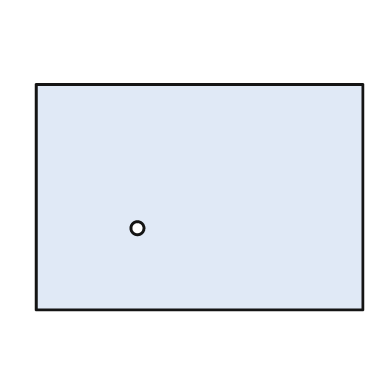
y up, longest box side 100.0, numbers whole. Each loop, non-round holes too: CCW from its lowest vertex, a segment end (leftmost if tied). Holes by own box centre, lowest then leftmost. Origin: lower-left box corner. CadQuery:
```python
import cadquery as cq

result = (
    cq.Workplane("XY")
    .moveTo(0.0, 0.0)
    .lineTo(100.0, 0.0)
    .lineTo(100.0, 69.0)
    .lineTo(0.0, 69.0)
    .close()
    .moveTo(31.0, 25.0)
    .circle(2.0)
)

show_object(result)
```